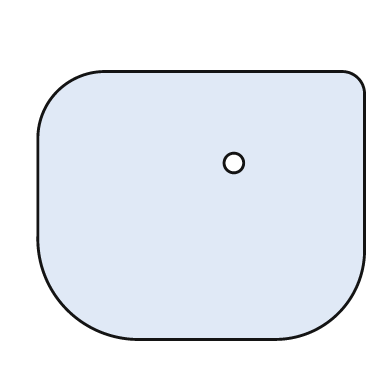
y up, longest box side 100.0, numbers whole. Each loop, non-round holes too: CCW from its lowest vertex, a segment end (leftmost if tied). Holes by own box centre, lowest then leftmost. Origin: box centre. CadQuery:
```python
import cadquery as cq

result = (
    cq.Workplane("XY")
    .moveTo(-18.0, -41.0)
    .lineTo(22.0, -41.0)
    .threePointArc((42.0, -33.0), (50.0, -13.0))
    .lineTo(50.0, 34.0)
    .threePointArc((48.0, 39.0), (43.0, 41.0))
    .lineTo(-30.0, 41.0)
    .threePointArc((-44.0, 35.0), (-50.0, 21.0))
    .lineTo(-50.0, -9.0)
    .threePointArc((-41.0, -32.0), (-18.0, -41.0))
    .close()
    .moveTo(10.0, 13.0)
    .circle(3.0)
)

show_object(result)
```